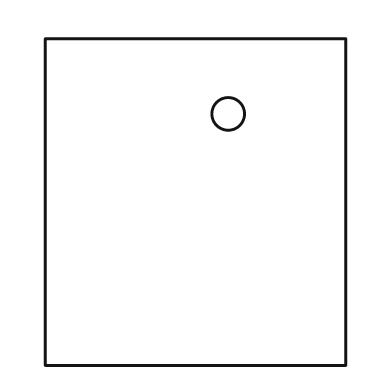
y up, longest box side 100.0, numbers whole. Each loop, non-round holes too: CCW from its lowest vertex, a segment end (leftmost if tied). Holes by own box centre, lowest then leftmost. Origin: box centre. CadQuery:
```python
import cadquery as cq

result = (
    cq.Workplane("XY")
    .moveTo(-46.0, -50.0)
    .lineTo(46.0, -50.0)
    .lineTo(46.0, 50.0)
    .lineTo(-46.0, 50.0)
    .close()
    .moveTo(10.0, 27.0)
    .circle(5.0)
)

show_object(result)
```